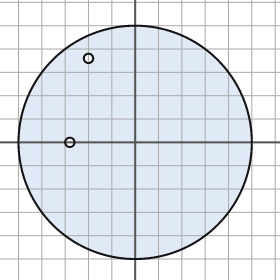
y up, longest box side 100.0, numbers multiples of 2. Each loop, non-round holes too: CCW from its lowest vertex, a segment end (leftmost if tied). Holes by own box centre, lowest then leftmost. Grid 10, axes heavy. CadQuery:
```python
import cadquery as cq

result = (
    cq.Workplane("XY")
    .moveTo(0.0, 0.0)
    .circle(50.0)
    .moveTo(-28.0, 0.0)
    .circle(2.0)
    .moveTo(-20.0, 36.0)
    .circle(2.0)
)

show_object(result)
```